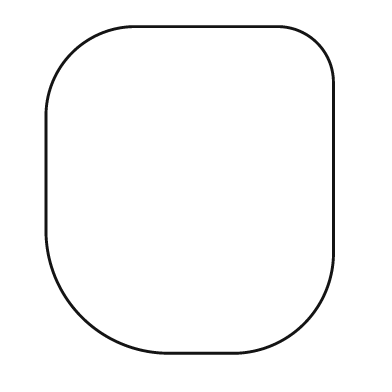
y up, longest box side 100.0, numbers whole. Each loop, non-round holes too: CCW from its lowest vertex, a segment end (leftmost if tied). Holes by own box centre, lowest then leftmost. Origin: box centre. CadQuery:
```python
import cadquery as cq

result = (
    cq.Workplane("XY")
    .moveTo(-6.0, -50.0)
    .lineTo(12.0, -50.0)
    .threePointArc((35.0, -41.0), (44.0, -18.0))
    .lineTo(44.0, 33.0)
    .threePointArc((39.0, 45.0), (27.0, 50.0))
    .lineTo(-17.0, 50.0)
    .threePointArc((-36.0, 42.0), (-44.0, 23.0))
    .lineTo(-44.0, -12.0)
    .threePointArc((-33.0, -39.0), (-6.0, -50.0))
    .close()
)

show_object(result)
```